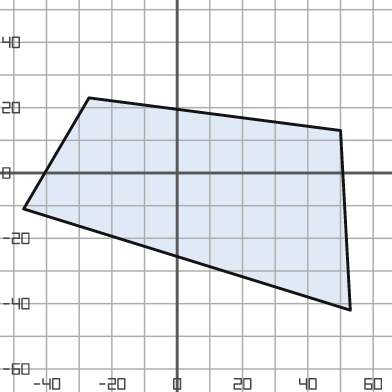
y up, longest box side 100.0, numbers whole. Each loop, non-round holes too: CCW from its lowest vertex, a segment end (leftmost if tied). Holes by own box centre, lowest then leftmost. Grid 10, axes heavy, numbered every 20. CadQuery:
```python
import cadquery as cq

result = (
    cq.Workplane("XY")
    .moveTo(53.0, -42.0)
    .lineTo(50.0, 13.0)
    .lineTo(-27.0, 23.0)
    .lineTo(-47.0, -11.0)
    .close()
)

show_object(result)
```